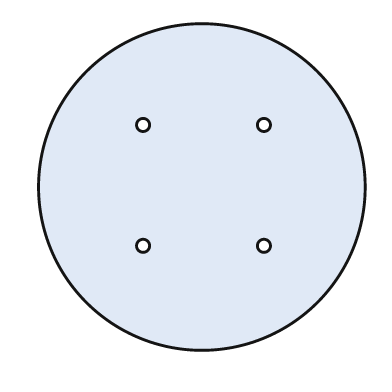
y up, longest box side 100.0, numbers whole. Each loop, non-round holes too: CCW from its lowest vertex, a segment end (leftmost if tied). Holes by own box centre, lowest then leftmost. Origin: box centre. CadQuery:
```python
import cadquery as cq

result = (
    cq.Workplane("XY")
    .moveTo(0.0, 0.0)
    .circle(50.0)
    .moveTo(-18.0, -18.0)
    .circle(2.0)
    .moveTo(19.0, -18.0)
    .circle(2.0)
    .moveTo(-18.0, 19.0)
    .circle(2.0)
    .moveTo(19.0, 19.0)
    .circle(2.0)
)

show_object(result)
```